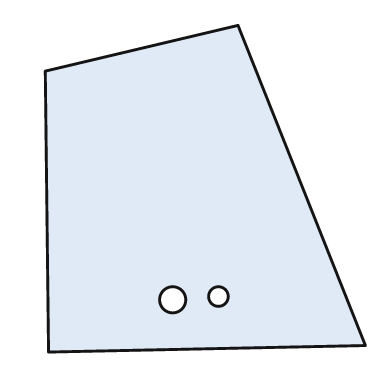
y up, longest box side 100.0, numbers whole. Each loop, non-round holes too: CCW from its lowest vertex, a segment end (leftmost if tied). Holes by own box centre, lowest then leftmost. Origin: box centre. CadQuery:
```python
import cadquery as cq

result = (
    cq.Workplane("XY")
    .moveTo(-48.0, -50.0)
    .lineTo(49.0, -48.0)
    .lineTo(10.0, 50.0)
    .lineTo(-49.0, 36.0)
    .close()
    .moveTo(-10.0, -34.0)
    .circle(4.0)
    .moveTo(4.0, -33.0)
    .circle(3.0)
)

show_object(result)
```